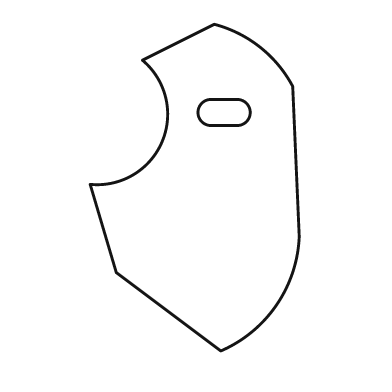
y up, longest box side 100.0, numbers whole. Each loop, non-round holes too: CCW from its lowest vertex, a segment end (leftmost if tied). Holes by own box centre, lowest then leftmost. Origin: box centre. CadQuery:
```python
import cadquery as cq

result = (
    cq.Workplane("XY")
    .moveTo(8.0, -50.0)
    .threePointArc((25.0, -36.0), (32.0, -15.0))
    .lineTo(30.0, 31.0)
    .threePointArc((20.0, 43.0), (6.0, 50.0))
    .lineTo(-16.0, 39.0)
    .threePointArc((-10.0, 14.0), (-32.0, 1.0))
    .lineTo(-24.0, -26.0)
    .close()
    .moveTo(5.0, 19.0)
    .lineTo(13.0, 19.0)
    .threePointArc((17.0, 23.0), (13.0, 27.0))
    .lineTo(5.0, 27.0)
    .threePointArc((1.0, 23.0), (5.0, 19.0))
    .close()
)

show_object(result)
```